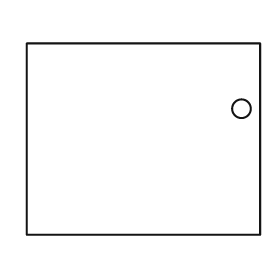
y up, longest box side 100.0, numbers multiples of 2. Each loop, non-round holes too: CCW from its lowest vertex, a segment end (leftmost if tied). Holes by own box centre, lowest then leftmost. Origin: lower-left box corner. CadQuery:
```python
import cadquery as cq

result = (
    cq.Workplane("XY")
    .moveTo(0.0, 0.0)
    .lineTo(100.0, 0.0)
    .lineTo(100.0, 82.0)
    .lineTo(0.0, 82.0)
    .close()
    .moveTo(92.0, 54.0)
    .circle(4.0)
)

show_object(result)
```